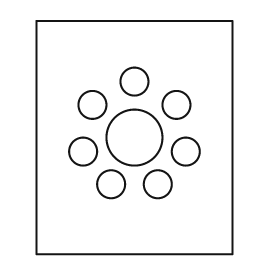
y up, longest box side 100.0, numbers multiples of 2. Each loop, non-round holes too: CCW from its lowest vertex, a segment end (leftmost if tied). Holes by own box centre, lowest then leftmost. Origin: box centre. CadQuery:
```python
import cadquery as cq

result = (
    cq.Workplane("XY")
    .moveTo(-42.0, -50.0)
    .lineTo(42.0, -50.0)
    .lineTo(42.0, 50.0)
    .lineTo(-42.0, 50.0)
    .close()
    .moveTo(-10.0, -20.0)
    .circle(6.0)
    .moveTo(10.0, -20.0)
    .circle(6.0)
    .moveTo(-22.0, -6.0)
    .circle(6.0)
    .moveTo(22.0, -6.0)
    .circle(6.0)
    .moveTo(0.0, 0.0)
    .circle(12.0)
    .moveTo(-18.0, 14.0)
    .circle(6.0)
    .moveTo(18.0, 14.0)
    .circle(6.0)
    .moveTo(0.0, 24.0)
    .circle(6.0)
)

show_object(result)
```